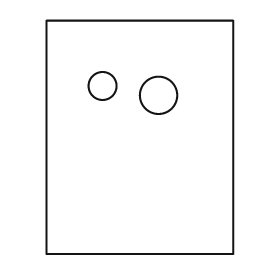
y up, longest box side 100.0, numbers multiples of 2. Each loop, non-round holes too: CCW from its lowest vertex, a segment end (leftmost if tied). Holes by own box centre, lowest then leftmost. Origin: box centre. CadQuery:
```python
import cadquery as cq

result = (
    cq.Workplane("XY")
    .moveTo(-40.0, -50.0)
    .lineTo(40.0, -50.0)
    .lineTo(40.0, 50.0)
    .lineTo(-40.0, 50.0)
    .close()
    .moveTo(8.0, 18.0)
    .circle(8.0)
    .moveTo(-16.0, 22.0)
    .circle(6.0)
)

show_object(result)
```